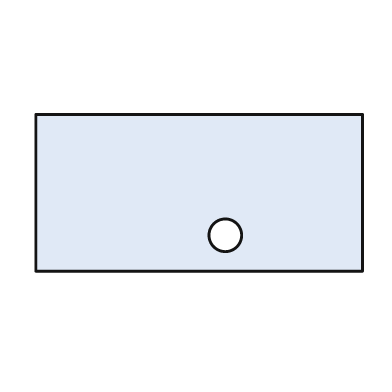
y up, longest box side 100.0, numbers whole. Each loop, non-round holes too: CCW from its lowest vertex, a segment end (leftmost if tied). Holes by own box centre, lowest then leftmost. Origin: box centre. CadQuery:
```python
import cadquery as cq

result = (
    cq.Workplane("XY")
    .moveTo(-50.0, -24.0)
    .lineTo(50.0, -24.0)
    .lineTo(50.0, 24.0)
    .lineTo(-50.0, 24.0)
    .close()
    .moveTo(8.0, -13.0)
    .circle(5.0)
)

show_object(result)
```